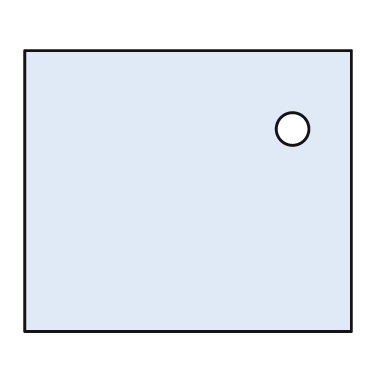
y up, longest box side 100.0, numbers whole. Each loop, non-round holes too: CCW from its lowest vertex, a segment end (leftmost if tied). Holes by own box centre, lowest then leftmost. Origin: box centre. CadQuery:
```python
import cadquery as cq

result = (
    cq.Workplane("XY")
    .moveTo(-50.0, -43.0)
    .lineTo(50.0, -43.0)
    .lineTo(50.0, 43.0)
    .lineTo(-50.0, 43.0)
    .close()
    .moveTo(32.0, 19.0)
    .circle(5.0)
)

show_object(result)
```